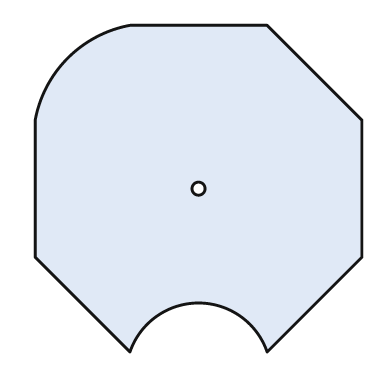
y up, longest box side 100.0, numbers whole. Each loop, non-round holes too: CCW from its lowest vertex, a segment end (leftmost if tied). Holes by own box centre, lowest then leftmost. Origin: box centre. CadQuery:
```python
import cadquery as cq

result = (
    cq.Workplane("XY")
    .moveTo(-21.0, -50.0)
    .threePointArc((0.0, -35.0), (21.0, -50.0))
    .lineTo(50.0, -21.0)
    .lineTo(50.0, 21.0)
    .lineTo(21.0, 50.0)
    .lineTo(-21.0, 50.0)
    .threePointArc((-40.0, 40.0), (-50.0, 21.0))
    .lineTo(-50.0, -21.0)
    .close()
    .moveTo(0.0, 0.0)
    .circle(2.0)
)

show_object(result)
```